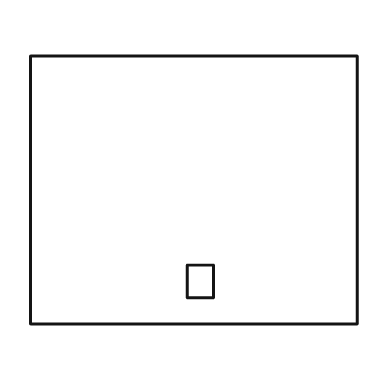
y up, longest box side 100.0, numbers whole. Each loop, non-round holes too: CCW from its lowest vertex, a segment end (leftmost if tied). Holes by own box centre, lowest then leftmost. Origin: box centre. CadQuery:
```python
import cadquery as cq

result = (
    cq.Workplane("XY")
    .moveTo(-50.0, -41.0)
    .lineTo(50.0, -41.0)
    .lineTo(50.0, 41.0)
    .lineTo(-50.0, 41.0)
    .close()
    .moveTo(-2.0, -33.0)
    .lineTo(6.0, -33.0)
    .lineTo(6.0, -23.0)
    .lineTo(-2.0, -23.0)
    .close()
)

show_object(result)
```